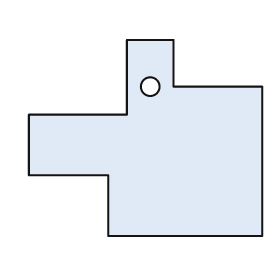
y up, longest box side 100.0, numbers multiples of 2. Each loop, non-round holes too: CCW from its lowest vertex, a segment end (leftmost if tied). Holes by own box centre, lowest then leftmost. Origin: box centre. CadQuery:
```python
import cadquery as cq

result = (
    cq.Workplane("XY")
    .moveTo(-16.0, -42.0)
    .lineTo(50.0, -42.0)
    .lineTo(50.0, 22.0)
    .lineTo(12.0, 22.0)
    .lineTo(12.0, 42.0)
    .lineTo(-8.0, 42.0)
    .lineTo(-8.0, 10.0)
    .lineTo(-50.0, 10.0)
    .lineTo(-50.0, -16.0)
    .lineTo(-16.0, -16.0)
    .close()
    .moveTo(2.0, 22.0)
    .circle(4.0)
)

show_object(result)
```